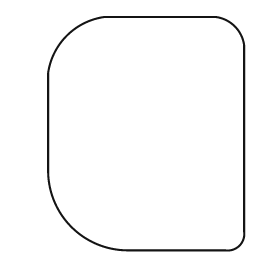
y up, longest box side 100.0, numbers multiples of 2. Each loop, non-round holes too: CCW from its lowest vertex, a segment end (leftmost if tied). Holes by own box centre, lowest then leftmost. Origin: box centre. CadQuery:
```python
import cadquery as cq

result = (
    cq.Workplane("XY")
    .moveTo(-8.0, -50.0)
    .lineTo(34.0, -50.0)
    .threePointArc((40.0, -48.0), (42.0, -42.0))
    .lineTo(42.0, 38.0)
    .threePointArc((38.0, 46.0), (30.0, 50.0))
    .lineTo(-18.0, 50.0)
    .threePointArc((-34.0, 42.0), (-42.0, 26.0))
    .lineTo(-42.0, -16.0)
    .threePointArc((-32.0, -40.0), (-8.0, -50.0))
    .close()
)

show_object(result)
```